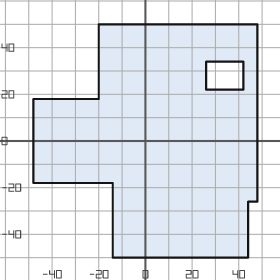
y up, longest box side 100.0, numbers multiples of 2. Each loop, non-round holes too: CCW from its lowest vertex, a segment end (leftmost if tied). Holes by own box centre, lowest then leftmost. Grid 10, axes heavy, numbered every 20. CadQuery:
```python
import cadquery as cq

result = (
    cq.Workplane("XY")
    .moveTo(-14.0, -50.0)
    .lineTo(44.0, -50.0)
    .lineTo(44.0, -26.0)
    .lineTo(48.0, -26.0)
    .lineTo(48.0, 50.0)
    .lineTo(-20.0, 50.0)
    .lineTo(-20.0, 18.0)
    .lineTo(-48.0, 18.0)
    .lineTo(-48.0, -18.0)
    .lineTo(-14.0, -18.0)
    .close()
    .moveTo(26.0, 22.0)
    .lineTo(42.0, 22.0)
    .lineTo(42.0, 34.0)
    .lineTo(26.0, 34.0)
    .close()
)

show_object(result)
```